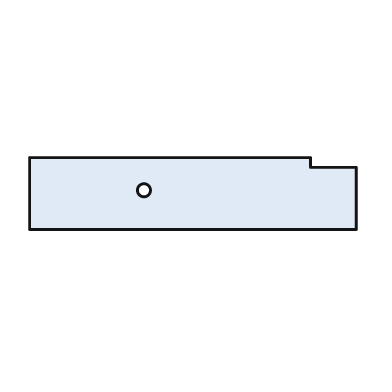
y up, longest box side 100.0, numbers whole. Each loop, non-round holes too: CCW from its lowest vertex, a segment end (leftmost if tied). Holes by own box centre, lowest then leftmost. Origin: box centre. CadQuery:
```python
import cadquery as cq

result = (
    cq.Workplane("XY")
    .moveTo(-50.0, -11.0)
    .lineTo(50.0, -11.0)
    .lineTo(50.0, 8.0)
    .lineTo(36.0, 8.0)
    .lineTo(36.0, 11.0)
    .lineTo(-50.0, 11.0)
    .close()
    .moveTo(-15.0, 1.0)
    .circle(2.0)
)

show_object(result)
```